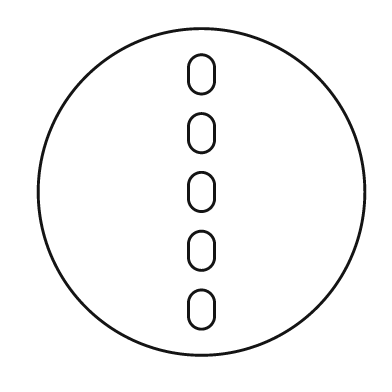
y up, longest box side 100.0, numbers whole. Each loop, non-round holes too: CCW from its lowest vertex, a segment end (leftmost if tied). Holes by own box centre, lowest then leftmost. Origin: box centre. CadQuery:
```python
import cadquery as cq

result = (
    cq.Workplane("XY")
    .moveTo(0.0, 0.0)
    .circle(50.0)
    .moveTo(-4.0, -38.0)
    .threePointArc((0.0, -42.0), (4.0, -38.0))
    .lineTo(4.0, -34.0)
    .threePointArc((0.0, -30.0), (-4.0, -34.0))
    .close()
    .moveTo(-4.0, -20.0)
    .threePointArc((0.0, -24.0), (4.0, -20.0))
    .lineTo(4.0, -16.0)
    .threePointArc((0.0, -12.0), (-4.0, -16.0))
    .close()
    .moveTo(-4.0, -2.0)
    .threePointArc((0.0, -6.0), (4.0, -2.0))
    .lineTo(4.0, 2.0)
    .threePointArc((0.0, 6.0), (-4.0, 2.0))
    .close()
    .moveTo(-4.0, 16.0)
    .threePointArc((0.0, 12.0), (4.0, 16.0))
    .lineTo(4.0, 20.0)
    .threePointArc((0.0, 24.0), (-4.0, 20.0))
    .close()
    .moveTo(-4.0, 34.0)
    .threePointArc((0.0, 30.0), (4.0, 34.0))
    .lineTo(4.0, 38.0)
    .threePointArc((0.0, 42.0), (-4.0, 38.0))
    .close()
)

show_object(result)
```